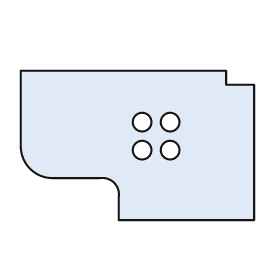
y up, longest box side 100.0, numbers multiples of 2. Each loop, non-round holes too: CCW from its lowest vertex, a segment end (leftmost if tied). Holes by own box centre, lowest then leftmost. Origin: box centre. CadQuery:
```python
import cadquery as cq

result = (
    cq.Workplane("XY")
    .moveTo(-8.0, -32.0)
    .lineTo(50.0, -32.0)
    .lineTo(50.0, 26.0)
    .lineTo(38.0, 26.0)
    .lineTo(38.0, 32.0)
    .lineTo(-50.0, 32.0)
    .lineTo(-50.0, 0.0)
    .threePointArc((-46.0, -10.0), (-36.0, -14.0))
    .lineTo(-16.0, -14.0)
    .threePointArc((-10.0, -16.0), (-8.0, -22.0))
    .close()
    .moveTo(2.0, -2.0)
    .circle(4.0)
    .moveTo(14.0, -2.0)
    .circle(4.0)
    .moveTo(2.0, 10.0)
    .circle(4.0)
    .moveTo(14.0, 10.0)
    .circle(4.0)
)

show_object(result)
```